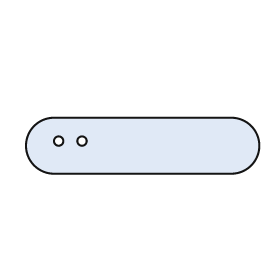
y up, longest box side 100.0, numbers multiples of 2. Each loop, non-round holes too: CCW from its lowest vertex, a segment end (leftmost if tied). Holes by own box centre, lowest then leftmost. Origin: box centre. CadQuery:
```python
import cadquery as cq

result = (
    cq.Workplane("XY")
    .moveTo(-38.0, -12.0)
    .lineTo(38.0, -12.0)
    .threePointArc((50.0, 0.0), (38.0, 12.0))
    .lineTo(-38.0, 12.0)
    .threePointArc((-50.0, 0.0), (-38.0, -12.0))
    .close()
    .moveTo(-36.0, 2.0)
    .circle(2.0)
    .moveTo(-26.0, 2.0)
    .circle(2.0)
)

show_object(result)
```